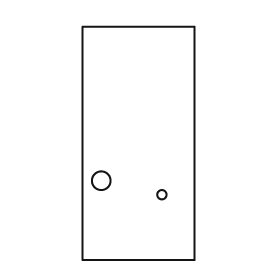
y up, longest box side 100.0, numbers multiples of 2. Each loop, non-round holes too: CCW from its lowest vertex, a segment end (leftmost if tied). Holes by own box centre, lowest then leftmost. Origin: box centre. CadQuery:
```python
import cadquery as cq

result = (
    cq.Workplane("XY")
    .moveTo(-24.0, -50.0)
    .lineTo(24.0, -50.0)
    .lineTo(24.0, 50.0)
    .lineTo(-24.0, 50.0)
    .close()
    .moveTo(10.0, -22.0)
    .circle(2.0)
    .moveTo(-16.0, -16.0)
    .circle(4.0)
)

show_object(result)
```